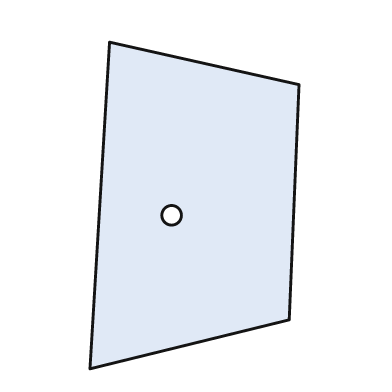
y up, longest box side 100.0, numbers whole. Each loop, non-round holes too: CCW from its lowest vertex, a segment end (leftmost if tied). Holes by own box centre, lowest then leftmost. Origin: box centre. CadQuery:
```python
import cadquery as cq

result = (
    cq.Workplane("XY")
    .moveTo(-32.0, -50.0)
    .lineTo(29.0, -35.0)
    .lineTo(32.0, 37.0)
    .lineTo(-26.0, 50.0)
    .close()
    .moveTo(-7.0, -3.0)
    .circle(3.0)
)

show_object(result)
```